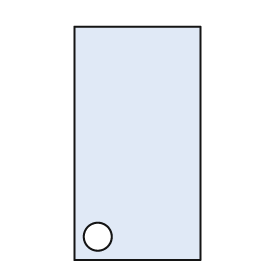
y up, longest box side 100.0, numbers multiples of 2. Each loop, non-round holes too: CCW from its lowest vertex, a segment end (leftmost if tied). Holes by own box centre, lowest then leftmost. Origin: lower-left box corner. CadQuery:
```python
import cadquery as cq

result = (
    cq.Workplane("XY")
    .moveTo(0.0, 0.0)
    .lineTo(54.0, 0.0)
    .lineTo(54.0, 100.0)
    .lineTo(0.0, 100.0)
    .close()
    .moveTo(10.0, 10.0)
    .circle(6.0)
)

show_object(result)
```